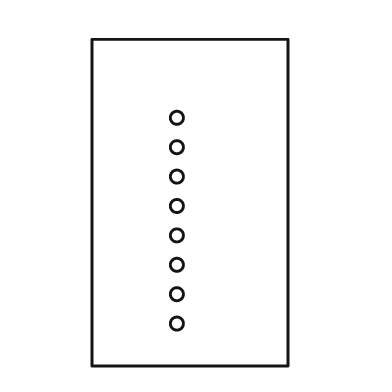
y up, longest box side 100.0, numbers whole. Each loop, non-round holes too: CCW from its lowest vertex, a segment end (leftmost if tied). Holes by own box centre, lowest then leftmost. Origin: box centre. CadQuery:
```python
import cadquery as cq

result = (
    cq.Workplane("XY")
    .moveTo(-30.0, -50.0)
    .lineTo(30.0, -50.0)
    .lineTo(30.0, 50.0)
    .lineTo(-30.0, 50.0)
    .close()
    .moveTo(-4.0, -37.0)
    .circle(2.0)
    .moveTo(-4.0, -28.0)
    .circle(2.0)
    .moveTo(-4.0, -19.0)
    .circle(2.0)
    .moveTo(-4.0, -10.0)
    .circle(2.0)
    .moveTo(-4.0, -1.0)
    .circle(2.0)
    .moveTo(-4.0, 8.0)
    .circle(2.0)
    .moveTo(-4.0, 17.0)
    .circle(2.0)
    .moveTo(-4.0, 26.0)
    .circle(2.0)
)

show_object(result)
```